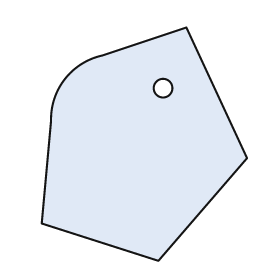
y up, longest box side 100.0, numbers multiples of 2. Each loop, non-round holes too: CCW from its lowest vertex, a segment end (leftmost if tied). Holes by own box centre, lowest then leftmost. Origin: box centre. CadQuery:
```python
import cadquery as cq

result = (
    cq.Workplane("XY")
    .moveTo(6.0, -50.0)
    .lineTo(44.0, -6.0)
    .lineTo(18.0, 50.0)
    .lineTo(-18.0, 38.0)
    .threePointArc((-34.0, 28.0), (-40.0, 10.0))
    .lineTo(-44.0, -34.0)
    .close()
    .moveTo(8.0, 24.0)
    .circle(4.0)
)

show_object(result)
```